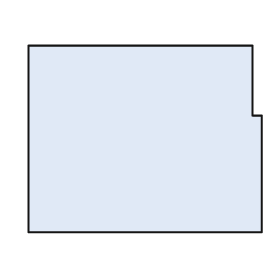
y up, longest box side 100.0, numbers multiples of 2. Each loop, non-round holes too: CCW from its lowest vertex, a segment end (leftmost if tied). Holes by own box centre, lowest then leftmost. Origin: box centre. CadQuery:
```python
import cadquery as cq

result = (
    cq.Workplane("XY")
    .moveTo(-50.0, -40.0)
    .lineTo(50.0, -40.0)
    .lineTo(50.0, 10.0)
    .lineTo(46.0, 10.0)
    .lineTo(46.0, 40.0)
    .lineTo(-50.0, 40.0)
    .close()
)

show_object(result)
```